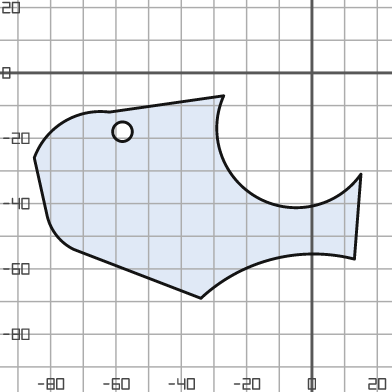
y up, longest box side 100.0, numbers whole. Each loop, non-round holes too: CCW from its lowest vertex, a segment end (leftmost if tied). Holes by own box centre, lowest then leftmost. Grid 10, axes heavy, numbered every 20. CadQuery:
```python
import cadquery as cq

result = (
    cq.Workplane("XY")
    .moveTo(-34.0, -69.0)
    .threePointArc((-12.0, -57.0), (13.0, -57.0))
    .lineTo(15.0, -31.0)
    .threePointArc((-17.0, -38.0), (-27.0, -7.0))
    .lineTo(-62.0, -12.0)
    .threePointArc((-76.0, -15.0), (-85.0, -26.0))
    .lineTo(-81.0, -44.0)
    .threePointArc((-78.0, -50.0), (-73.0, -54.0))
    .close()
    .moveTo(-58.0, -18.0)
    .circle(3.0)
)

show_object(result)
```